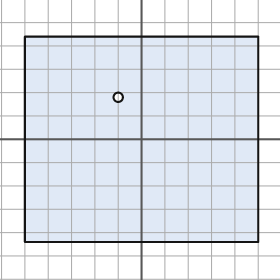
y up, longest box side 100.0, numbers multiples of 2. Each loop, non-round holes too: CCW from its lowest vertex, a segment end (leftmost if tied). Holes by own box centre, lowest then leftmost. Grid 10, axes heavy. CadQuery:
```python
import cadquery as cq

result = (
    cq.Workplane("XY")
    .moveTo(-50.0, -44.0)
    .lineTo(50.0, -44.0)
    .lineTo(50.0, 44.0)
    .lineTo(-50.0, 44.0)
    .close()
    .moveTo(-10.0, 18.0)
    .circle(2.0)
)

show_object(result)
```